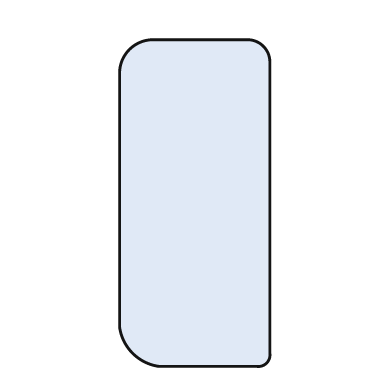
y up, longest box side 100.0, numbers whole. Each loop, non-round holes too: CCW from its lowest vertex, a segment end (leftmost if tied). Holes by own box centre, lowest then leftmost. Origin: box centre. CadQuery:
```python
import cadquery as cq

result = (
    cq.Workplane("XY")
    .moveTo(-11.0, -50.0)
    .lineTo(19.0, -50.0)
    .threePointArc((22.0, -49.0), (23.0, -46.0))
    .lineTo(23.0, 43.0)
    .threePointArc((21.0, 48.0), (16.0, 50.0))
    .lineTo(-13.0, 50.0)
    .threePointArc((-20.0, 47.0), (-23.0, 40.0))
    .lineTo(-23.0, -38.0)
    .threePointArc((-19.0, -46.0), (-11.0, -50.0))
    .close()
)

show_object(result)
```